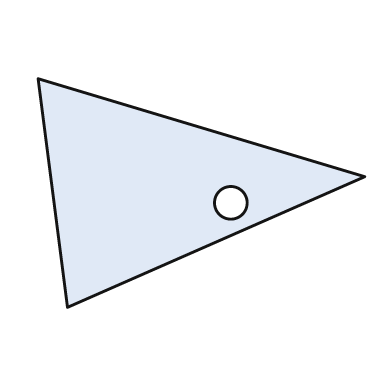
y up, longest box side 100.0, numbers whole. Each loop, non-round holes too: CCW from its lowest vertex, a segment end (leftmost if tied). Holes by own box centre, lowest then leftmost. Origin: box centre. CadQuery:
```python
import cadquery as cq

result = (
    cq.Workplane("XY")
    .moveTo(-41.0, -35.0)
    .lineTo(50.0, 5.0)
    .lineTo(-50.0, 35.0)
    .close()
    .moveTo(9.0, -3.0)
    .circle(5.0)
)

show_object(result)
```